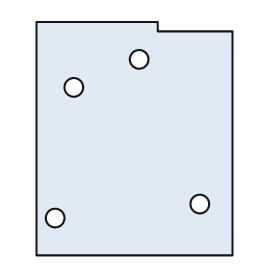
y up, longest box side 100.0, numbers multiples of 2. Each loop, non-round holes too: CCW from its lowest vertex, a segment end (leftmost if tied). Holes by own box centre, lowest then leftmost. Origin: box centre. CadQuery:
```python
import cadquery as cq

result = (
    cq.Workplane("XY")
    .moveTo(-42.0, -50.0)
    .lineTo(42.0, -50.0)
    .lineTo(42.0, 46.0)
    .lineTo(10.0, 46.0)
    .lineTo(10.0, 50.0)
    .lineTo(-42.0, 50.0)
    .close()
    .moveTo(-34.0, -34.0)
    .circle(4.0)
    .moveTo(28.0, -28.0)
    .circle(4.0)
    .moveTo(-26.0, 22.0)
    .circle(4.0)
    .moveTo(2.0, 34.0)
    .circle(4.0)
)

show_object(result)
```